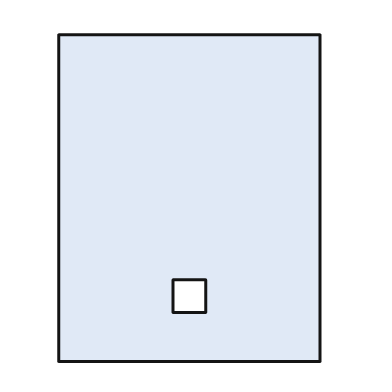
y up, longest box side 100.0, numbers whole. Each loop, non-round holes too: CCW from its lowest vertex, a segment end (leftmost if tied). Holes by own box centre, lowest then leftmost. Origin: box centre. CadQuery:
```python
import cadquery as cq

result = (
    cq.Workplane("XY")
    .moveTo(-40.0, -50.0)
    .lineTo(40.0, -50.0)
    .lineTo(40.0, 50.0)
    .lineTo(-40.0, 50.0)
    .close()
    .moveTo(-5.0, -35.0)
    .lineTo(5.0, -35.0)
    .lineTo(5.0, -25.0)
    .lineTo(-5.0, -25.0)
    .close()
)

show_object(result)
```